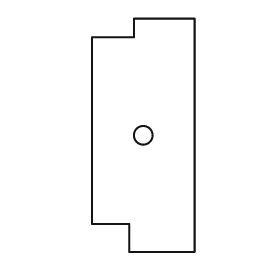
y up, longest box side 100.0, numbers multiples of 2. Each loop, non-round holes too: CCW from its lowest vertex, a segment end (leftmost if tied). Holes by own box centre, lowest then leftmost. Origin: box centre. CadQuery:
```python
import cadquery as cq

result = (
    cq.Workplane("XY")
    .moveTo(-6.0, -50.0)
    .lineTo(22.0, -50.0)
    .lineTo(22.0, 50.0)
    .lineTo(-4.0, 50.0)
    .lineTo(-4.0, 42.0)
    .lineTo(-22.0, 42.0)
    .lineTo(-22.0, -38.0)
    .lineTo(-6.0, -38.0)
    .close()
    .moveTo(0.0, 0.0)
    .circle(4.0)
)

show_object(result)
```